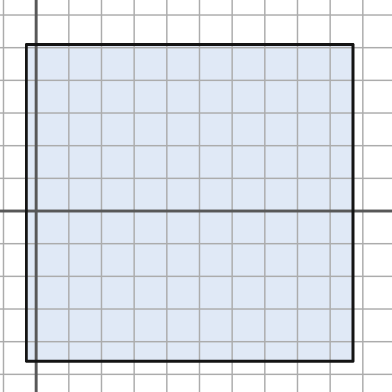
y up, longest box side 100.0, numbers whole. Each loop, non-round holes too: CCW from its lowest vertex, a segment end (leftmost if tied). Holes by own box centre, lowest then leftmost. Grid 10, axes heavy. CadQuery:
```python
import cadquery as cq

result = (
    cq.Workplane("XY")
    .moveTo(-3.0, -46.0)
    .lineTo(97.0, -46.0)
    .lineTo(97.0, 51.0)
    .lineTo(-3.0, 51.0)
    .close()
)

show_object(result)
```